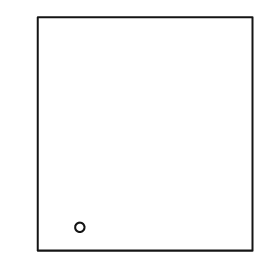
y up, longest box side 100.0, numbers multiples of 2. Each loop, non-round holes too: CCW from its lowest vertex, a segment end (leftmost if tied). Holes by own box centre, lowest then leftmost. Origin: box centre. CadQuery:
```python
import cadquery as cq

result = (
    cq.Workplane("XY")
    .moveTo(-46.0, -50.0)
    .lineTo(46.0, -50.0)
    .lineTo(46.0, 50.0)
    .lineTo(-46.0, 50.0)
    .close()
    .moveTo(-28.0, -40.0)
    .circle(2.0)
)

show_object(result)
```